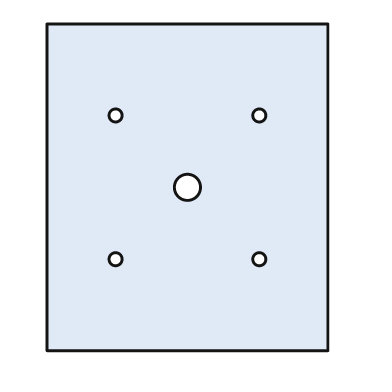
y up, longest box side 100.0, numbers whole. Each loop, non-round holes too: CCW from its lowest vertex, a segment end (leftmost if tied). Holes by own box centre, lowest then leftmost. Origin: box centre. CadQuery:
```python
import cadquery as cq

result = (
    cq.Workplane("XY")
    .moveTo(-43.0, -50.0)
    .lineTo(43.0, -50.0)
    .lineTo(43.0, 50.0)
    .lineTo(-43.0, 50.0)
    .close()
    .moveTo(-22.0, -22.0)
    .circle(2.0)
    .moveTo(22.0, -22.0)
    .circle(2.0)
    .moveTo(0.0, 0.0)
    .circle(4.0)
    .moveTo(-22.0, 22.0)
    .circle(2.0)
    .moveTo(22.0, 22.0)
    .circle(2.0)
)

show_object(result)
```